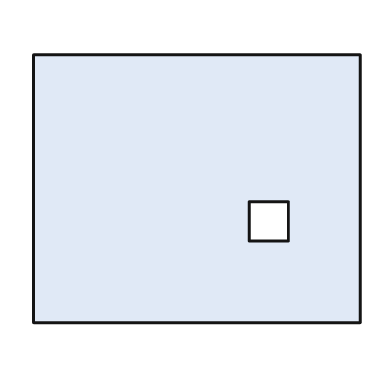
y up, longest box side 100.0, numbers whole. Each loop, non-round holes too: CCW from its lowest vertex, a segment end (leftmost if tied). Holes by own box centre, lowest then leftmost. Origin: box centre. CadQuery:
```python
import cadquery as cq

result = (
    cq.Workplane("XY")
    .moveTo(-50.0, -41.0)
    .lineTo(50.0, -41.0)
    .lineTo(50.0, 41.0)
    .lineTo(-50.0, 41.0)
    .close()
    .moveTo(16.0, -16.0)
    .lineTo(28.0, -16.0)
    .lineTo(28.0, -4.0)
    .lineTo(16.0, -4.0)
    .close()
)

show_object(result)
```